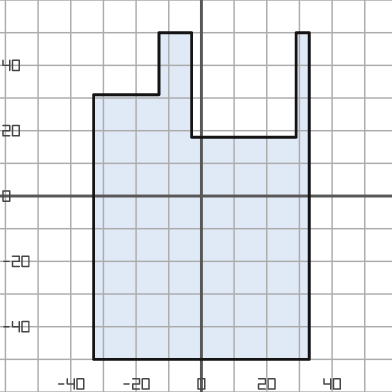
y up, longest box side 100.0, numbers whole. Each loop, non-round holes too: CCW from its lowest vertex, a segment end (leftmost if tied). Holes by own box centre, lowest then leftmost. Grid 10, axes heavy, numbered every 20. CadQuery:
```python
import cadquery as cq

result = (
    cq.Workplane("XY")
    .moveTo(-33.0, -50.0)
    .lineTo(33.0, -50.0)
    .lineTo(33.0, 50.0)
    .lineTo(29.0, 50.0)
    .lineTo(29.0, 18.0)
    .lineTo(-3.0, 18.0)
    .lineTo(-3.0, 50.0)
    .lineTo(-13.0, 50.0)
    .lineTo(-13.0, 31.0)
    .lineTo(-33.0, 31.0)
    .close()
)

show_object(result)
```